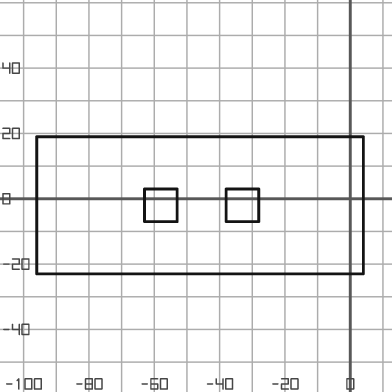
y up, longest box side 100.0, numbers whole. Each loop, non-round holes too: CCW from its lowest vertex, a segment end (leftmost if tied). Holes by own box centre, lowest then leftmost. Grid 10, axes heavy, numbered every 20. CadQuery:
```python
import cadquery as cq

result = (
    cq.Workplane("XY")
    .moveTo(-96.0, -23.0)
    .lineTo(4.0, -23.0)
    .lineTo(4.0, 19.0)
    .lineTo(-96.0, 19.0)
    .close()
    .moveTo(-63.0, -7.0)
    .lineTo(-53.0, -7.0)
    .lineTo(-53.0, 3.0)
    .lineTo(-63.0, 3.0)
    .close()
    .moveTo(-38.0, -7.0)
    .lineTo(-28.0, -7.0)
    .lineTo(-28.0, 3.0)
    .lineTo(-38.0, 3.0)
    .close()
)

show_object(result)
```